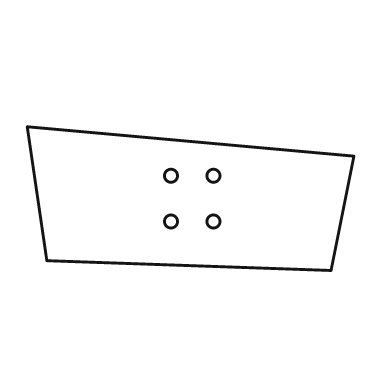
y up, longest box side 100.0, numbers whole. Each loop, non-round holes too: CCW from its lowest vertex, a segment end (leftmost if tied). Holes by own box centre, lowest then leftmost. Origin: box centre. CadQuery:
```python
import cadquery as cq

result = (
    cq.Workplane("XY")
    .moveTo(43.0, -22.0)
    .lineTo(50.0, 13.0)
    .lineTo(-50.0, 22.0)
    .lineTo(-44.0, -19.0)
    .close()
    .moveTo(-6.0, -7.0)
    .circle(2.0)
    .moveTo(7.0, -7.0)
    .circle(2.0)
    .moveTo(-6.0, 7.0)
    .circle(2.0)
    .moveTo(7.0, 7.0)
    .circle(2.0)
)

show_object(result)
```